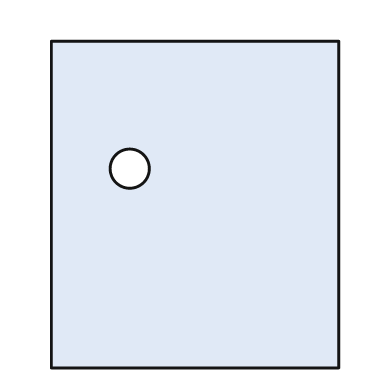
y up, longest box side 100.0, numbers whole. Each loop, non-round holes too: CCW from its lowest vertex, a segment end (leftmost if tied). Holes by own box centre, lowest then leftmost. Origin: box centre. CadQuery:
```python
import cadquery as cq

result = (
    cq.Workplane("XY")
    .moveTo(-44.0, -50.0)
    .lineTo(44.0, -50.0)
    .lineTo(44.0, 50.0)
    .lineTo(-44.0, 50.0)
    .close()
    .moveTo(-20.0, 11.0)
    .circle(6.0)
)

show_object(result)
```